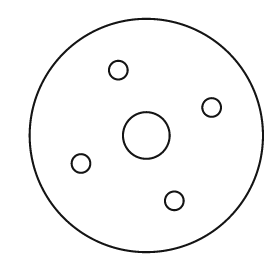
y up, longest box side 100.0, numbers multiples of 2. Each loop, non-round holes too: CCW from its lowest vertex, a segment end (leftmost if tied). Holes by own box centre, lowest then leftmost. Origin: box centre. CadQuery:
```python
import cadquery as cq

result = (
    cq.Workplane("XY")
    .moveTo(0.0, 0.0)
    .circle(50.0)
    .moveTo(12.0, -28.0)
    .circle(4.0)
    .moveTo(-28.0, -12.0)
    .circle(4.0)
    .moveTo(0.0, 0.0)
    .circle(10.0)
    .moveTo(28.0, 12.0)
    .circle(4.0)
    .moveTo(-12.0, 28.0)
    .circle(4.0)
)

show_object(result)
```